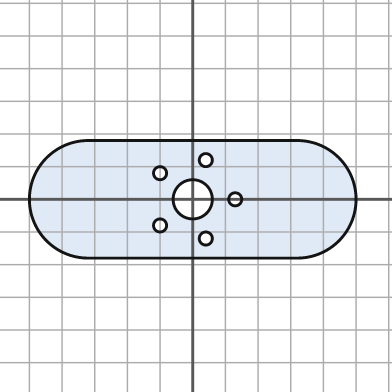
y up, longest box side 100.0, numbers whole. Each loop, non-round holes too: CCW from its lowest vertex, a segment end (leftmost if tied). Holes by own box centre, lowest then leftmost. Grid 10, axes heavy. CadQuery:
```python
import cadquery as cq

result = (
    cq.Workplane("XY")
    .moveTo(-32.0, -18.0)
    .lineTo(32.0, -18.0)
    .threePointArc((50.0, 0.0), (32.0, 18.0))
    .lineTo(-32.0, 18.0)
    .threePointArc((-50.0, 0.0), (-32.0, -18.0))
    .close()
    .moveTo(4.0, -12.0)
    .circle(2.0)
    .moveTo(-10.0, -8.0)
    .circle(2.0)
    .moveTo(0.0, 0.0)
    .circle(6.0)
    .moveTo(13.0, 0.0)
    .circle(2.0)
    .moveTo(-10.0, 8.0)
    .circle(2.0)
    .moveTo(4.0, 12.0)
    .circle(2.0)
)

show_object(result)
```